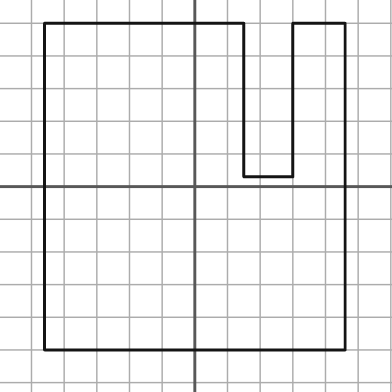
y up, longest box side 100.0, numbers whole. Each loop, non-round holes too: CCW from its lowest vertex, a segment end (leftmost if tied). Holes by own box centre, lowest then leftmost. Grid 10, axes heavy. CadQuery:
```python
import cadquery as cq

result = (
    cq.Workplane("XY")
    .moveTo(-46.0, -50.0)
    .lineTo(46.0, -50.0)
    .lineTo(46.0, 50.0)
    .lineTo(30.0, 50.0)
    .lineTo(30.0, 3.0)
    .lineTo(15.0, 3.0)
    .lineTo(15.0, 50.0)
    .lineTo(-46.0, 50.0)
    .close()
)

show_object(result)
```